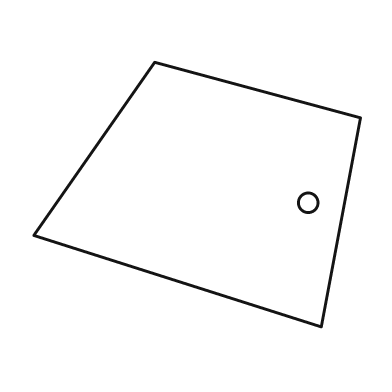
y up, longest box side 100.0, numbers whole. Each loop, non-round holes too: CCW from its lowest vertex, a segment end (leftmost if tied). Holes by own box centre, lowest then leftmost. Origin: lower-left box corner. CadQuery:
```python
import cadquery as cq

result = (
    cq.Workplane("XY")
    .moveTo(88.0, 0.0)
    .lineTo(100.0, 64.0)
    .lineTo(37.0, 81.0)
    .lineTo(0.0, 28.0)
    .close()
    .moveTo(84.0, 38.0)
    .circle(3.0)
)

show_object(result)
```